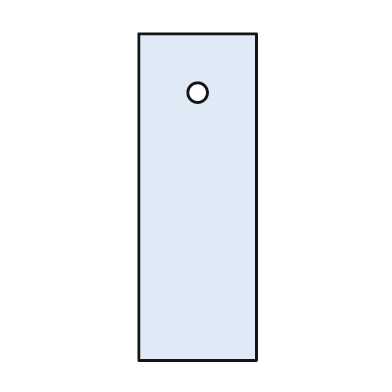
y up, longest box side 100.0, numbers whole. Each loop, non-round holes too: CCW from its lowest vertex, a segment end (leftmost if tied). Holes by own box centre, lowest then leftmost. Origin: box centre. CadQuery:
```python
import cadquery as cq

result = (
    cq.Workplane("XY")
    .moveTo(-18.0, -50.0)
    .lineTo(18.0, -50.0)
    .lineTo(18.0, 50.0)
    .lineTo(-18.0, 50.0)
    .close()
    .moveTo(0.0, 32.0)
    .circle(3.0)
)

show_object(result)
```